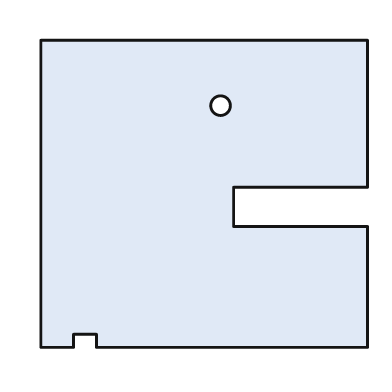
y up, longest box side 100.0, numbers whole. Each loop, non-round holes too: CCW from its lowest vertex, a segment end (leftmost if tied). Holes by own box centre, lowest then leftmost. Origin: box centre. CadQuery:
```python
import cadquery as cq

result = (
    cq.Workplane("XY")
    .moveTo(-50.0, -47.0)
    .lineTo(-40.0, -47.0)
    .lineTo(-40.0, -43.0)
    .lineTo(-33.0, -43.0)
    .lineTo(-33.0, -47.0)
    .lineTo(50.0, -47.0)
    .lineTo(50.0, -10.0)
    .lineTo(9.0, -10.0)
    .lineTo(9.0, 2.0)
    .lineTo(50.0, 2.0)
    .lineTo(50.0, 47.0)
    .lineTo(-50.0, 47.0)
    .close()
    .moveTo(5.0, 27.0)
    .circle(3.0)
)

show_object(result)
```